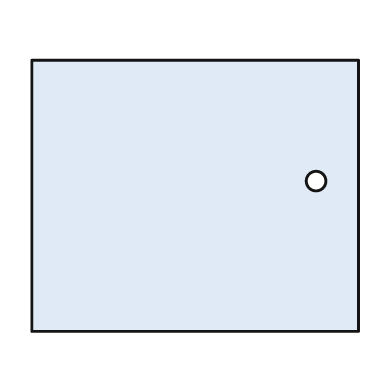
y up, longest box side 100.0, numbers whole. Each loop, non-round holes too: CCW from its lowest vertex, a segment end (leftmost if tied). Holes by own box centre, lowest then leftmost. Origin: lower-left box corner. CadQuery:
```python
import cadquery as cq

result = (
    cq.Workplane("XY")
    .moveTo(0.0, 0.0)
    .lineTo(100.0, 0.0)
    .lineTo(100.0, 83.0)
    .lineTo(0.0, 83.0)
    .close()
    .moveTo(87.0, 46.0)
    .circle(3.0)
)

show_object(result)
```